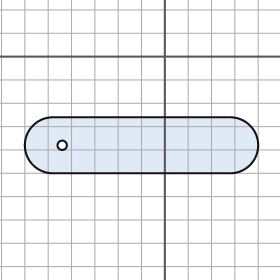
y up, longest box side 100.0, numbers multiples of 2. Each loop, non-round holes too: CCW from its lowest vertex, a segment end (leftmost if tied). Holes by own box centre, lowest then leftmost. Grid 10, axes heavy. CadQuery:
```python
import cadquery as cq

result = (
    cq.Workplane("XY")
    .moveTo(-48.0, -50.0)
    .lineTo(28.0, -50.0)
    .threePointArc((40.0, -38.0), (28.0, -26.0))
    .lineTo(-48.0, -26.0)
    .threePointArc((-60.0, -38.0), (-48.0, -50.0))
    .close()
    .moveTo(-44.0, -38.0)
    .circle(2.0)
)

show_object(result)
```